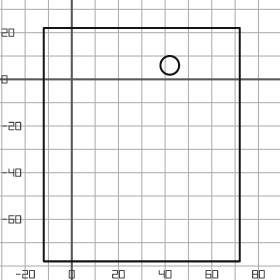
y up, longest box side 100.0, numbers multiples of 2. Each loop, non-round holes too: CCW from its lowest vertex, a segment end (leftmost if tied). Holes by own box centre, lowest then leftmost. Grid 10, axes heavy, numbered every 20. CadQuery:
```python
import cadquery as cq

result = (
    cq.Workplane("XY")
    .moveTo(-12.0, -78.0)
    .lineTo(72.0, -78.0)
    .lineTo(72.0, 22.0)
    .lineTo(-12.0, 22.0)
    .close()
    .moveTo(42.0, 6.0)
    .circle(4.0)
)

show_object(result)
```